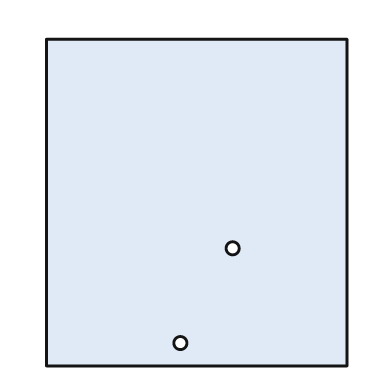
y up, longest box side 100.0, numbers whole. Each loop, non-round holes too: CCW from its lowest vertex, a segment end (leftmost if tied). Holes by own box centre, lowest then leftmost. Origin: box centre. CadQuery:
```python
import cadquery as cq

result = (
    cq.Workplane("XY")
    .moveTo(-46.0, -50.0)
    .lineTo(46.0, -50.0)
    .lineTo(46.0, 50.0)
    .lineTo(-46.0, 50.0)
    .close()
    .moveTo(-5.0, -43.0)
    .circle(2.0)
    .moveTo(11.0, -14.0)
    .circle(2.0)
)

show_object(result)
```